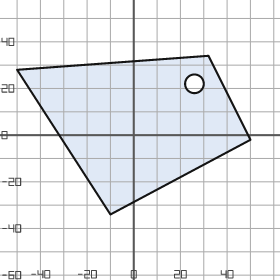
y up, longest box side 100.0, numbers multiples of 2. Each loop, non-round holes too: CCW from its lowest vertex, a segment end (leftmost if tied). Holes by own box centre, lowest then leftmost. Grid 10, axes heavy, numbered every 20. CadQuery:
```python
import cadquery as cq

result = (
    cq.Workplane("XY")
    .moveTo(-10.0, -34.0)
    .lineTo(50.0, -2.0)
    .lineTo(32.0, 34.0)
    .lineTo(-50.0, 28.0)
    .close()
    .moveTo(26.0, 22.0)
    .circle(4.0)
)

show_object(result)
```